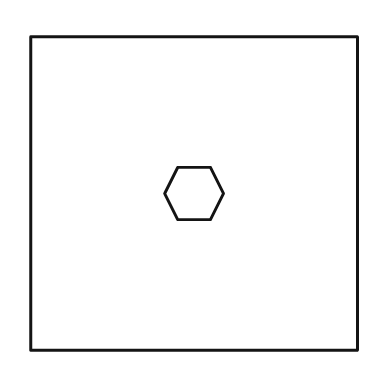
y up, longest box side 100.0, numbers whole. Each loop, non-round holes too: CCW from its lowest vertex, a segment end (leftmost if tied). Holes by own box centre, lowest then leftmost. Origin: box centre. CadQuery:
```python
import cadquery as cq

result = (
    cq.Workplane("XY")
    .moveTo(-50.0, -48.0)
    .lineTo(50.0, -48.0)
    .lineTo(50.0, 48.0)
    .lineTo(-50.0, 48.0)
    .close()
    .moveTo(-5.0, -8.0)
    .lineTo(5.0, -8.0)
    .lineTo(9.0, 0.0)
    .lineTo(5.0, 8.0)
    .lineTo(-5.0, 8.0)
    .lineTo(-9.0, 0.0)
    .close()
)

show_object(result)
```